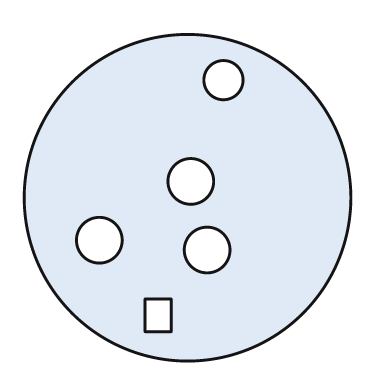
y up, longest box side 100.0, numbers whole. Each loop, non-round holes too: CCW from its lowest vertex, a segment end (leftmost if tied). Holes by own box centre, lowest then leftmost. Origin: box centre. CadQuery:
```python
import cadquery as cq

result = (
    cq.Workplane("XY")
    .moveTo(0.0, 0.0)
    .circle(50.0)
    .moveTo(-13.0, -41.0)
    .lineTo(-5.0, -41.0)
    .lineTo(-5.0, -31.0)
    .lineTo(-13.0, -31.0)
    .close()
    .moveTo(6.0, -16.0)
    .circle(7.0)
    .moveTo(-27.0, -13.0)
    .circle(7.0)
    .moveTo(1.0, 5.0)
    .circle(7.0)
    .moveTo(11.0, 36.0)
    .circle(6.0)
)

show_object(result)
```